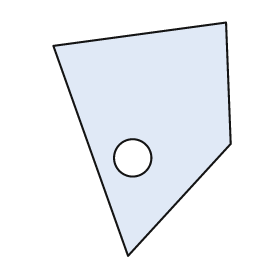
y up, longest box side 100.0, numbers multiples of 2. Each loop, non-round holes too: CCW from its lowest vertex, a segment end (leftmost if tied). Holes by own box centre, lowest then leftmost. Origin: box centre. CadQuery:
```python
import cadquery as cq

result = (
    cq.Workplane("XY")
    .moveTo(-6.0, -50.0)
    .lineTo(38.0, -2.0)
    .lineTo(36.0, 50.0)
    .lineTo(-38.0, 40.0)
    .close()
    .moveTo(-4.0, -8.0)
    .circle(8.0)
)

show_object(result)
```